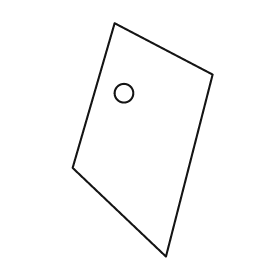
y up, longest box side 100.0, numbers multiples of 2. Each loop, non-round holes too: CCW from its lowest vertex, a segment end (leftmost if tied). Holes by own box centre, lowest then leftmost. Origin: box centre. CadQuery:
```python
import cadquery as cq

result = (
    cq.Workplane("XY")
    .moveTo(10.0, -50.0)
    .lineTo(30.0, 28.0)
    .lineTo(-12.0, 50.0)
    .lineTo(-30.0, -12.0)
    .close()
    .moveTo(-8.0, 20.0)
    .circle(4.0)
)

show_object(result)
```